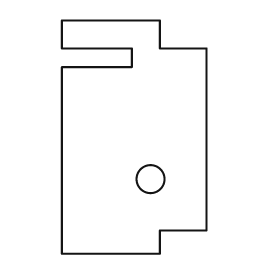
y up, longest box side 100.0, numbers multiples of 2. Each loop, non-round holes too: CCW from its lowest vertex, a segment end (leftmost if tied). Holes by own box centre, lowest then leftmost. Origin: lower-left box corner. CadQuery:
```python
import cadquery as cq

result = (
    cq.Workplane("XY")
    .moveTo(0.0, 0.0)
    .lineTo(42.0, 0.0)
    .lineTo(42.0, 10.0)
    .lineTo(62.0, 10.0)
    .lineTo(62.0, 88.0)
    .lineTo(42.0, 88.0)
    .lineTo(42.0, 100.0)
    .lineTo(0.0, 100.0)
    .lineTo(0.0, 88.0)
    .lineTo(30.0, 88.0)
    .lineTo(30.0, 80.0)
    .lineTo(0.0, 80.0)
    .close()
    .moveTo(38.0, 32.0)
    .circle(6.0)
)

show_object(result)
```